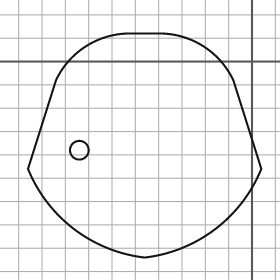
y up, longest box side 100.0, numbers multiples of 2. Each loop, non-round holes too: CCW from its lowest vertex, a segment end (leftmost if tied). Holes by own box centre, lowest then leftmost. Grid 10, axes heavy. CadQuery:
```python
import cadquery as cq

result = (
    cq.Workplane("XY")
    .moveTo(-46.0, -84.0)
    .threePointArc((-16.0, -72.0), (4.0, -46.0))
    .lineTo(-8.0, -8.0)
    .threePointArc((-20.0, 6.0), (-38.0, 12.0))
    .lineTo(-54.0, 12.0)
    .threePointArc((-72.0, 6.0), (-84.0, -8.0))
    .lineTo(-96.0, -46.0)
    .threePointArc((-76.0, -72.0), (-46.0, -84.0))
    .close()
    .moveTo(-74.0, -38.0)
    .circle(4.0)
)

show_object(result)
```